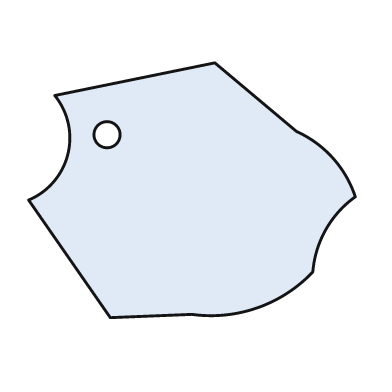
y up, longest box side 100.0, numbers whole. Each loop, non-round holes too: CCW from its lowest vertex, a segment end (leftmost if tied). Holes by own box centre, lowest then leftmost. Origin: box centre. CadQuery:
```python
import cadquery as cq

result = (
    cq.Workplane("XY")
    .moveTo(-25.0, -39.0)
    .lineTo(0.0, -38.0)
    .threePointArc((20.0, -36.0), (37.0, -25.0))
    .threePointArc((41.0, -12.0), (50.0, -2.0))
    .threePointArc((43.0, 10.0), (32.0, 18.0))
    .lineTo(7.0, 39.0)
    .lineTo(-42.0, 29.0)
    .threePointArc((-38.0, 11.0), (-50.0, -3.0))
    .close()
    .moveTo(-26.0, 17.0)
    .circle(4.0)
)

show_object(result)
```